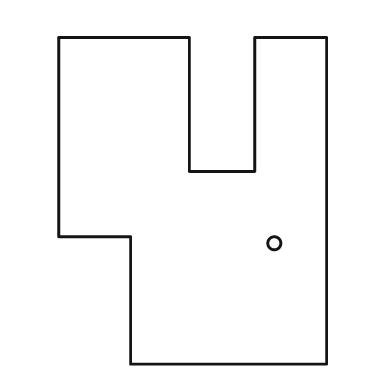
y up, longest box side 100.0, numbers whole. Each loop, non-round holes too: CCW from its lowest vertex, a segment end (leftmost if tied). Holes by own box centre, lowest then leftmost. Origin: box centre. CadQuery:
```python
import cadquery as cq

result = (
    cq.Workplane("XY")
    .moveTo(-19.0, -50.0)
    .lineTo(41.0, -50.0)
    .lineTo(41.0, 50.0)
    .lineTo(19.0, 50.0)
    .lineTo(19.0, 9.0)
    .lineTo(-1.0, 9.0)
    .lineTo(-1.0, 50.0)
    .lineTo(-41.0, 50.0)
    .lineTo(-41.0, -11.0)
    .lineTo(-19.0, -11.0)
    .close()
    .moveTo(25.0, -13.0)
    .circle(2.0)
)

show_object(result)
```